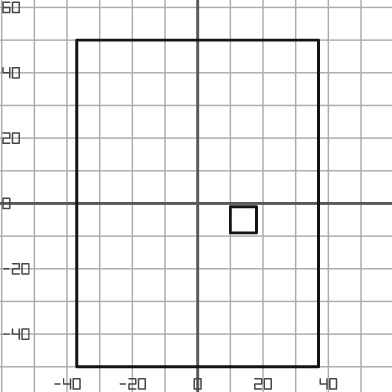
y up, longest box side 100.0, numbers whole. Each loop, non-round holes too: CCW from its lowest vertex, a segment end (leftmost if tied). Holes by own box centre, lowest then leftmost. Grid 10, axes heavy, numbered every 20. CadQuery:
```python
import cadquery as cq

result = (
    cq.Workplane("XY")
    .moveTo(-37.0, -50.0)
    .lineTo(37.0, -50.0)
    .lineTo(37.0, 50.0)
    .lineTo(-37.0, 50.0)
    .close()
    .moveTo(10.0, -9.0)
    .lineTo(18.0, -9.0)
    .lineTo(18.0, -1.0)
    .lineTo(10.0, -1.0)
    .close()
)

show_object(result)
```